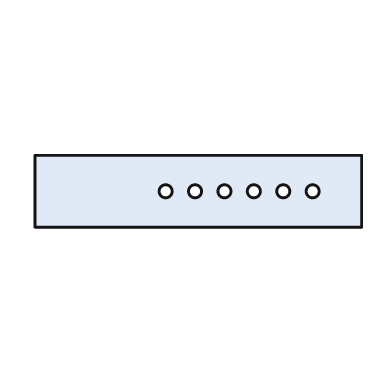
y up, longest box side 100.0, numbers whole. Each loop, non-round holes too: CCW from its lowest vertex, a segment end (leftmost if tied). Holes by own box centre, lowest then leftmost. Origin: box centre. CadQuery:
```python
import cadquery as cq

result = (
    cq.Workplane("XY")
    .moveTo(-50.0, -11.0)
    .lineTo(50.0, -11.0)
    .lineTo(50.0, 11.0)
    .lineTo(-50.0, 11.0)
    .close()
    .moveTo(-10.0, 0.0)
    .circle(2.0)
    .moveTo(-1.0, 0.0)
    .circle(2.0)
    .moveTo(8.0, 0.0)
    .circle(2.0)
    .moveTo(17.0, 0.0)
    .circle(2.0)
    .moveTo(26.0, 0.0)
    .circle(2.0)
    .moveTo(35.0, 0.0)
    .circle(2.0)
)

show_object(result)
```